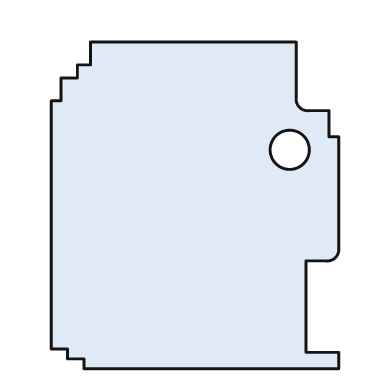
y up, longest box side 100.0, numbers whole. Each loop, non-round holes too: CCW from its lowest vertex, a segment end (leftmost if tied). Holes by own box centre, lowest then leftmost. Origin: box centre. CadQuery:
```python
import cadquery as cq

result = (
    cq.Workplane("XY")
    .moveTo(-34.0, -50.0)
    .lineTo(44.0, -50.0)
    .lineTo(44.0, -45.0)
    .lineTo(34.0, -45.0)
    .lineTo(34.0, -17.0)
    .lineTo(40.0, -17.0)
    .threePointArc((43.0, -16.0), (44.0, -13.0))
    .lineTo(44.0, 21.0)
    .lineTo(41.0, 21.0)
    .lineTo(41.0, 29.0)
    .lineTo(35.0, 29.0)
    .threePointArc((32.0, 30.0), (31.0, 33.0))
    .lineTo(31.0, 50.0)
    .lineTo(-32.0, 50.0)
    .lineTo(-32.0, 43.0)
    .lineTo(-36.0, 43.0)
    .lineTo(-36.0, 39.0)
    .lineTo(-41.0, 39.0)
    .lineTo(-41.0, 32.0)
    .lineTo(-44.0, 32.0)
    .lineTo(-44.0, -44.0)
    .lineTo(-39.0, -44.0)
    .lineTo(-39.0, -47.0)
    .lineTo(-34.0, -47.0)
    .close()
    .moveTo(29.0, 17.0)
    .circle(6.0)
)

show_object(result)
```